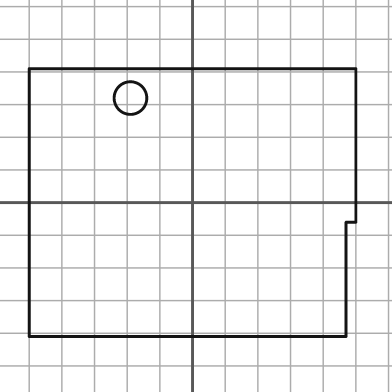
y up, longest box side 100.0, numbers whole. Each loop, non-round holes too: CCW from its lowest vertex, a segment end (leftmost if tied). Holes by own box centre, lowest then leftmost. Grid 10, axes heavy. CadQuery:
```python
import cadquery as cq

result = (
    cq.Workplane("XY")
    .moveTo(-50.0, -41.0)
    .lineTo(47.0, -41.0)
    .lineTo(47.0, -6.0)
    .lineTo(50.0, -6.0)
    .lineTo(50.0, 41.0)
    .lineTo(-50.0, 41.0)
    .close()
    .moveTo(-19.0, 32.0)
    .circle(5.0)
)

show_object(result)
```